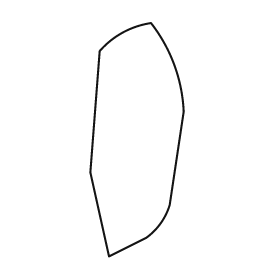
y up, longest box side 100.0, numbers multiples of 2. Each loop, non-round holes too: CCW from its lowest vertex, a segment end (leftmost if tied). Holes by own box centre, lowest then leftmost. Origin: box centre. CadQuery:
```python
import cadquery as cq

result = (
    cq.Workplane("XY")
    .moveTo(-12.0, -50.0)
    .lineTo(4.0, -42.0)
    .threePointArc((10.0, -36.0), (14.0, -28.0))
    .lineTo(20.0, 12.0)
    .threePointArc((16.0, 32.0), (6.0, 50.0))
    .threePointArc((-6.0, 46.0), (-16.0, 38.0))
    .lineTo(-20.0, -14.0)
    .close()
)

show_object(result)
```